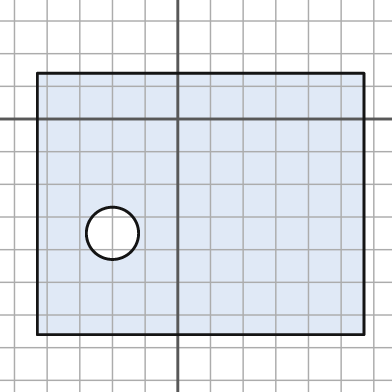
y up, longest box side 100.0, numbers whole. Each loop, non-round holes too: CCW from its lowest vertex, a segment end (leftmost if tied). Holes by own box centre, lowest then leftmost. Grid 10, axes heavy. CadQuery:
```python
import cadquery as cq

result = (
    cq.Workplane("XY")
    .moveTo(-43.0, -66.0)
    .lineTo(57.0, -66.0)
    .lineTo(57.0, 14.0)
    .lineTo(-43.0, 14.0)
    .close()
    .moveTo(-20.0, -35.0)
    .circle(8.0)
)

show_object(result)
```